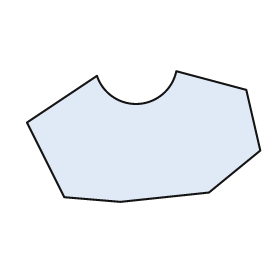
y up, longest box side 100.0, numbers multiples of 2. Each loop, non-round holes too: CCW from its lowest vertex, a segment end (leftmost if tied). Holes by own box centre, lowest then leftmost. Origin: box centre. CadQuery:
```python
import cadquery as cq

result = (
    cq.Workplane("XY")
    .moveTo(-10.0, -28.0)
    .lineTo(28.0, -24.0)
    .lineTo(50.0, -6.0)
    .lineTo(44.0, 20.0)
    .lineTo(14.0, 28.0)
    .threePointArc((-2.0, 14.0), (-20.0, 26.0))
    .lineTo(-50.0, 6.0)
    .lineTo(-34.0, -26.0)
    .close()
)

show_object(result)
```